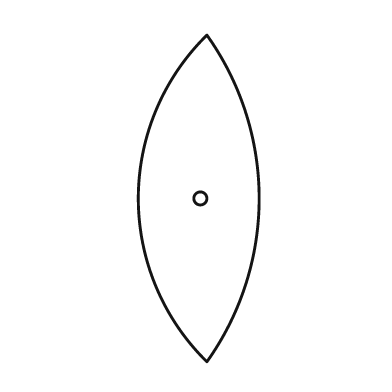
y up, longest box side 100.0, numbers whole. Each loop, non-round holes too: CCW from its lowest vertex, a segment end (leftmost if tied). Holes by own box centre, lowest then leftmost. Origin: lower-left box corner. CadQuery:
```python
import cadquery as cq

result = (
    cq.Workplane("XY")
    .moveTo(21.0, 0.0)
    .threePointArc((37.0, 50.0), (21.0, 100.0))
    .threePointArc((0.0, 50.0), (21.0, 0.0))
    .close()
    .moveTo(19.0, 50.0)
    .circle(2.0)
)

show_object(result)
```